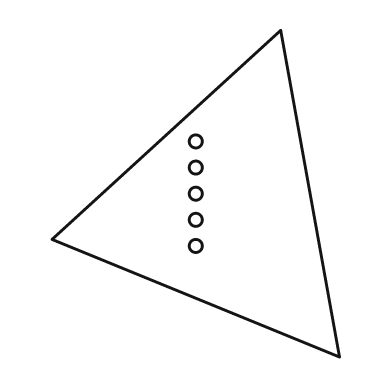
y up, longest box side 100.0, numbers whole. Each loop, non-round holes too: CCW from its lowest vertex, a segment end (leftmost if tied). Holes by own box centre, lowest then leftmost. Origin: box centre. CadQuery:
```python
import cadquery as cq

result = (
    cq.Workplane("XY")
    .moveTo(44.0, -50.0)
    .lineTo(26.0, 50.0)
    .lineTo(-44.0, -14.0)
    .close()
    .moveTo(0.0, -16.0)
    .circle(2.0)
    .moveTo(0.0, -8.0)
    .circle(2.0)
    .moveTo(0.0, 0.0)
    .circle(2.0)
    .moveTo(0.0, 8.0)
    .circle(2.0)
    .moveTo(0.0, 16.0)
    .circle(2.0)
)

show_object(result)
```